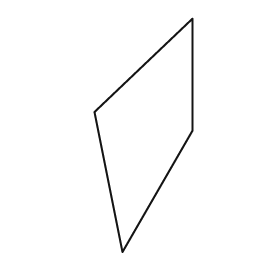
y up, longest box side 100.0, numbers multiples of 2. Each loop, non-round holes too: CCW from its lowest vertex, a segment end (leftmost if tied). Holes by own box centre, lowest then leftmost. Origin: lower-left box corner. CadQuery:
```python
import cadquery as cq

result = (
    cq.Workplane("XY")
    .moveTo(12.0, 0.0)
    .lineTo(42.0, 52.0)
    .lineTo(42.0, 100.0)
    .lineTo(0.0, 60.0)
    .close()
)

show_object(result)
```